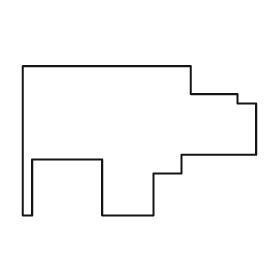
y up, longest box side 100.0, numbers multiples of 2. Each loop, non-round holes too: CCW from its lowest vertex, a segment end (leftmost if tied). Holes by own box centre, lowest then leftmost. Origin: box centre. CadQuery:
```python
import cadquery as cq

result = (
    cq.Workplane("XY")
    .moveTo(-50.0, -32.0)
    .lineTo(-46.0, -32.0)
    .lineTo(-46.0, -8.0)
    .lineTo(-16.0, -8.0)
    .lineTo(-16.0, -32.0)
    .lineTo(6.0, -32.0)
    .lineTo(6.0, -14.0)
    .lineTo(18.0, -14.0)
    .lineTo(18.0, -6.0)
    .lineTo(50.0, -6.0)
    .lineTo(50.0, 16.0)
    .lineTo(42.0, 16.0)
    .lineTo(42.0, 20.0)
    .lineTo(22.0, 20.0)
    .lineTo(22.0, 32.0)
    .lineTo(-50.0, 32.0)
    .close()
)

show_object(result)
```